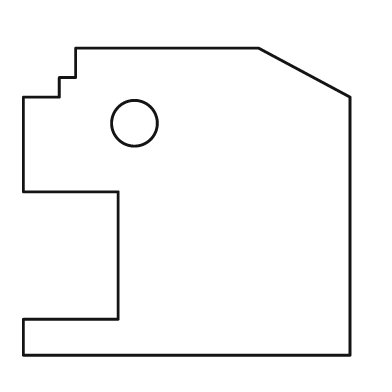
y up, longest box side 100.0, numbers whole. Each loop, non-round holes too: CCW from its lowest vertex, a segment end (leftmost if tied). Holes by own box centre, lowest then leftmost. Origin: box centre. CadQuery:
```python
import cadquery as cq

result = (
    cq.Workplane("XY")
    .moveTo(-50.0, -47.0)
    .lineTo(50.0, -47.0)
    .lineTo(50.0, 32.0)
    .lineTo(22.0, 47.0)
    .lineTo(-34.0, 47.0)
    .lineTo(-34.0, 38.0)
    .lineTo(-39.0, 38.0)
    .lineTo(-39.0, 32.0)
    .lineTo(-50.0, 32.0)
    .lineTo(-50.0, 3.0)
    .lineTo(-21.0, 3.0)
    .lineTo(-21.0, -36.0)
    .lineTo(-50.0, -36.0)
    .close()
    .moveTo(-16.0, 24.0)
    .circle(7.0)
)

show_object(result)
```